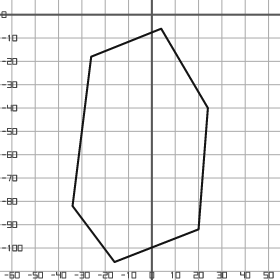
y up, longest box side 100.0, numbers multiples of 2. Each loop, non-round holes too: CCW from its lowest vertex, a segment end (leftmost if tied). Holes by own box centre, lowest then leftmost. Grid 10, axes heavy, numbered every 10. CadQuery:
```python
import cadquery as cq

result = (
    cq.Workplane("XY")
    .moveTo(-16.0, -106.0)
    .lineTo(20.0, -92.0)
    .lineTo(24.0, -40.0)
    .lineTo(4.0, -6.0)
    .lineTo(-26.0, -18.0)
    .lineTo(-34.0, -82.0)
    .close()
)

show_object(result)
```